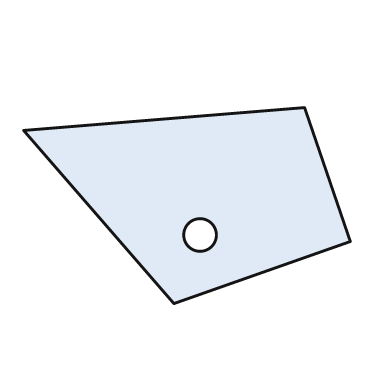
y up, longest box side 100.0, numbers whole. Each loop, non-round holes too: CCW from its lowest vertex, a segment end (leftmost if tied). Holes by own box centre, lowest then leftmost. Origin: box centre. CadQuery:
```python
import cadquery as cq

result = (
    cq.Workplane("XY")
    .moveTo(-4.0, -30.0)
    .lineTo(50.0, -11.0)
    .lineTo(36.0, 30.0)
    .lineTo(-50.0, 23.0)
    .close()
    .moveTo(4.0, -9.0)
    .circle(5.0)
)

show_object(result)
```